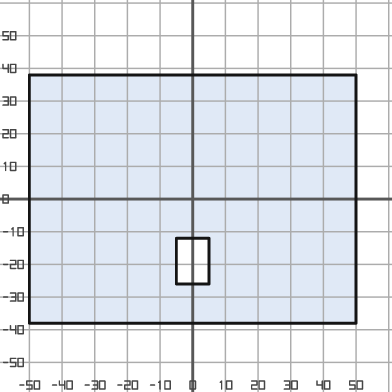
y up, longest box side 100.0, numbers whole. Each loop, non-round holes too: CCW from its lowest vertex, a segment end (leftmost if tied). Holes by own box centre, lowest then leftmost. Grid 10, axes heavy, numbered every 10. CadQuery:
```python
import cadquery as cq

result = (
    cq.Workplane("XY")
    .moveTo(-50.0, -38.0)
    .lineTo(50.0, -38.0)
    .lineTo(50.0, 38.0)
    .lineTo(-50.0, 38.0)
    .close()
    .moveTo(-5.0, -26.0)
    .lineTo(5.0, -26.0)
    .lineTo(5.0, -12.0)
    .lineTo(-5.0, -12.0)
    .close()
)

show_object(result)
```